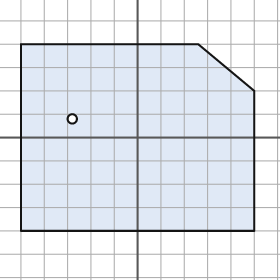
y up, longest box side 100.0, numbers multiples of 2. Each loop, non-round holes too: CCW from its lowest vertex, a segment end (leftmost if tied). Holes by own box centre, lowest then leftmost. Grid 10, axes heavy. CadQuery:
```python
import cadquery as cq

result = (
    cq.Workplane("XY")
    .moveTo(-50.0, -40.0)
    .lineTo(50.0, -40.0)
    .lineTo(50.0, 20.0)
    .lineTo(26.0, 40.0)
    .lineTo(-50.0, 40.0)
    .close()
    .moveTo(-28.0, 8.0)
    .circle(2.0)
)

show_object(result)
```